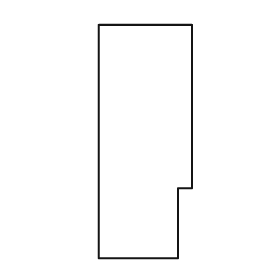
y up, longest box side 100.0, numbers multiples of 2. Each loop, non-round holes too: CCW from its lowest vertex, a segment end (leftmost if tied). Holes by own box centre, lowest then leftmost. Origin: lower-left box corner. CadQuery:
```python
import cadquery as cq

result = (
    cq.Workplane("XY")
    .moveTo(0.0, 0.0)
    .lineTo(34.0, 0.0)
    .lineTo(34.0, 30.0)
    .lineTo(40.0, 30.0)
    .lineTo(40.0, 100.0)
    .lineTo(0.0, 100.0)
    .close()
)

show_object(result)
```